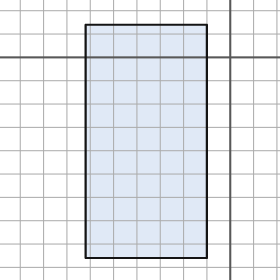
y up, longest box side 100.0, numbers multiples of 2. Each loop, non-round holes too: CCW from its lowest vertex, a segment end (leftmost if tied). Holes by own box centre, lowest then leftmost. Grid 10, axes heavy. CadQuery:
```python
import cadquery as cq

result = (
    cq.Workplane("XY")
    .moveTo(-62.0, -86.0)
    .lineTo(-10.0, -86.0)
    .lineTo(-10.0, 14.0)
    .lineTo(-62.0, 14.0)
    .close()
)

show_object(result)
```